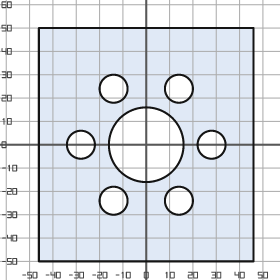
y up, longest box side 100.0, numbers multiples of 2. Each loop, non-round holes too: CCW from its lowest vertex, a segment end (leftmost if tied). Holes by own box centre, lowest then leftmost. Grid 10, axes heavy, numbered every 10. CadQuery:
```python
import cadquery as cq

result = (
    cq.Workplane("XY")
    .moveTo(-46.0, -50.0)
    .lineTo(46.0, -50.0)
    .lineTo(46.0, 50.0)
    .lineTo(-46.0, 50.0)
    .close()
    .moveTo(-14.0, -24.0)
    .circle(6.0)
    .moveTo(14.0, -24.0)
    .circle(6.0)
    .moveTo(-28.0, 0.0)
    .circle(6.0)
    .moveTo(0.0, 0.0)
    .circle(16.0)
    .moveTo(28.0, 0.0)
    .circle(6.0)
    .moveTo(-14.0, 24.0)
    .circle(6.0)
    .moveTo(14.0, 24.0)
    .circle(6.0)
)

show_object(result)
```